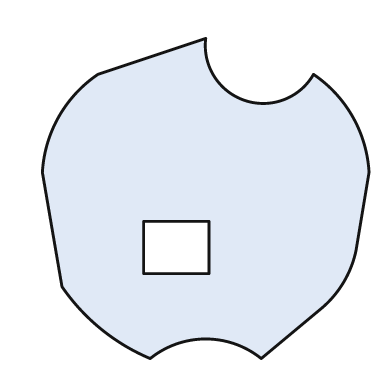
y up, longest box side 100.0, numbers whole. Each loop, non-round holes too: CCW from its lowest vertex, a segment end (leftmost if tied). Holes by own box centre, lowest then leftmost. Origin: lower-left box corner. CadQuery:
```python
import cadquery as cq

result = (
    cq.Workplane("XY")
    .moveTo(33.0, 0.0)
    .threePointArc((50.0, 6.0), (67.0, 0.0))
    .lineTo(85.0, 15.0)
    .threePointArc((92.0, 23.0), (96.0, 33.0))
    .lineTo(100.0, 57.0)
    .threePointArc((95.0, 74.0), (83.0, 87.0))
    .threePointArc((62.0, 79.0), (50.0, 98.0))
    .lineTo(17.0, 87.0)
    .threePointArc((5.0, 74.0), (0.0, 57.0))
    .lineTo(6.0, 22.0)
    .threePointArc((18.0, 9.0), (33.0, 0.0))
    .close()
    .moveTo(31.0, 26.0)
    .lineTo(51.0, 26.0)
    .lineTo(51.0, 42.0)
    .lineTo(31.0, 42.0)
    .close()
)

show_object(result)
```